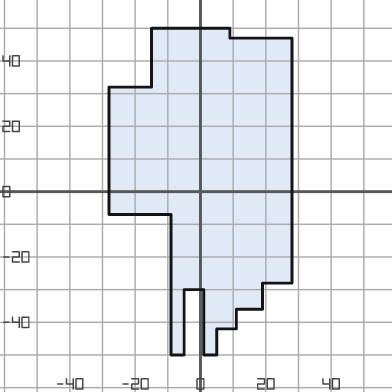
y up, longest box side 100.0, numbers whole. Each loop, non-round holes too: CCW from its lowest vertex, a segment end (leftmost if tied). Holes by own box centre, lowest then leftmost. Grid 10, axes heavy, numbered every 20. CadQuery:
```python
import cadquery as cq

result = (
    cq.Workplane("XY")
    .moveTo(-9.0, -50.0)
    .lineTo(-5.0, -50.0)
    .lineTo(-5.0, -30.0)
    .lineTo(1.0, -30.0)
    .lineTo(1.0, -50.0)
    .lineTo(5.0, -50.0)
    .lineTo(5.0, -42.0)
    .lineTo(11.0, -42.0)
    .lineTo(11.0, -36.0)
    .lineTo(19.0, -36.0)
    .lineTo(19.0, -28.0)
    .lineTo(28.0, -28.0)
    .lineTo(28.0, 47.0)
    .lineTo(9.0, 47.0)
    .lineTo(9.0, 50.0)
    .lineTo(-15.0, 50.0)
    .lineTo(-15.0, 32.0)
    .lineTo(-28.0, 32.0)
    .lineTo(-28.0, -7.0)
    .lineTo(-9.0, -7.0)
    .close()
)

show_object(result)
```